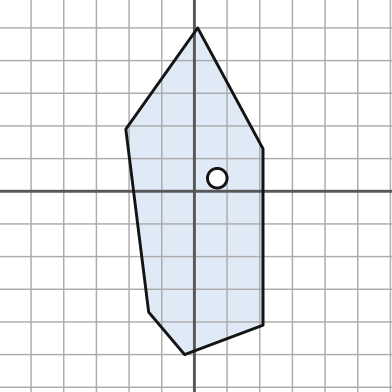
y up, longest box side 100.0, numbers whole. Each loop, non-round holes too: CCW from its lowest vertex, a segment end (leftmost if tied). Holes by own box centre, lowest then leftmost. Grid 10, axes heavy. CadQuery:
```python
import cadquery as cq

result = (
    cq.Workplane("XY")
    .moveTo(-3.0, -50.0)
    .lineTo(21.0, -41.0)
    .lineTo(21.0, 13.0)
    .lineTo(1.0, 50.0)
    .lineTo(-21.0, 19.0)
    .lineTo(-14.0, -37.0)
    .close()
    .moveTo(7.0, 4.0)
    .circle(3.0)
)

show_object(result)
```